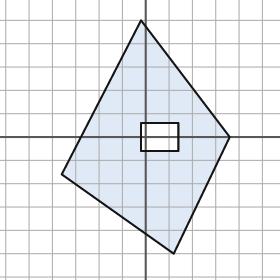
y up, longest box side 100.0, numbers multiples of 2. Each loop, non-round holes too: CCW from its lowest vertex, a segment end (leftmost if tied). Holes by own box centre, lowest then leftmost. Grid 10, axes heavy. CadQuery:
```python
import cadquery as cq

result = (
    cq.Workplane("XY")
    .moveTo(12.0, -50.0)
    .lineTo(36.0, 0.0)
    .lineTo(-2.0, 50.0)
    .lineTo(-36.0, -16.0)
    .close()
    .moveTo(-2.0, -6.0)
    .lineTo(14.0, -6.0)
    .lineTo(14.0, 6.0)
    .lineTo(-2.0, 6.0)
    .close()
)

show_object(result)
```